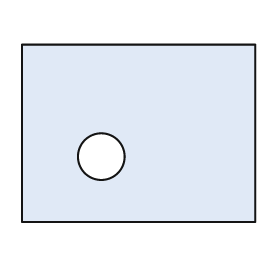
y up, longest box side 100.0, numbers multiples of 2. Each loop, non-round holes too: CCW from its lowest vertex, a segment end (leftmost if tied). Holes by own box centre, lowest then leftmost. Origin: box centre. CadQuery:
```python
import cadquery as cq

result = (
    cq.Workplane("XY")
    .moveTo(-50.0, -38.0)
    .lineTo(50.0, -38.0)
    .lineTo(50.0, 38.0)
    .lineTo(-50.0, 38.0)
    .close()
    .moveTo(-16.0, -10.0)
    .circle(10.0)
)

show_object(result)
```